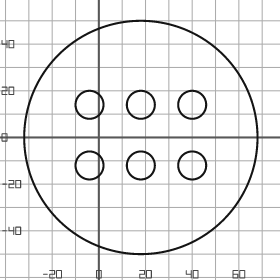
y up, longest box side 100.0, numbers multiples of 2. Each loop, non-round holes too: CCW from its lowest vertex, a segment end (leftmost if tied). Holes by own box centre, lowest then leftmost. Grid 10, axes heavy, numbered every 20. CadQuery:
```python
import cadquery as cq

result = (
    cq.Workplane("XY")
    .moveTo(18.0, 0.0)
    .circle(50.0)
    .moveTo(-4.0, -12.0)
    .circle(6.0)
    .moveTo(18.0, -12.0)
    .circle(6.0)
    .moveTo(40.0, -12.0)
    .circle(6.0)
    .moveTo(-4.0, 14.0)
    .circle(6.0)
    .moveTo(18.0, 14.0)
    .circle(6.0)
    .moveTo(40.0, 14.0)
    .circle(6.0)
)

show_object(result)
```